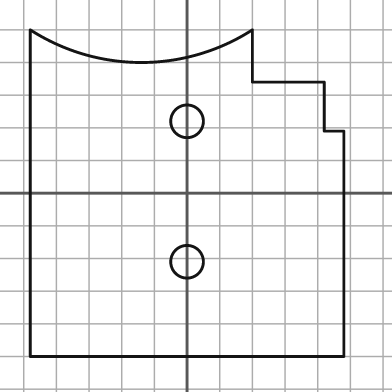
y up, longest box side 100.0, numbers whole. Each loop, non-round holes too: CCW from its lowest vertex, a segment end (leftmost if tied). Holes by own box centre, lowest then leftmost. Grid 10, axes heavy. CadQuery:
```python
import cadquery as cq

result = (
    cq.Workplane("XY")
    .moveTo(-48.0, -50.0)
    .lineTo(48.0, -50.0)
    .lineTo(48.0, 19.0)
    .lineTo(42.0, 19.0)
    .lineTo(42.0, 34.0)
    .lineTo(20.0, 34.0)
    .lineTo(20.0, 50.0)
    .threePointArc((-14.0, 40.0), (-48.0, 50.0))
    .close()
    .moveTo(0.0, -21.0)
    .circle(5.0)
    .moveTo(0.0, 22.0)
    .circle(5.0)
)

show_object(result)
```